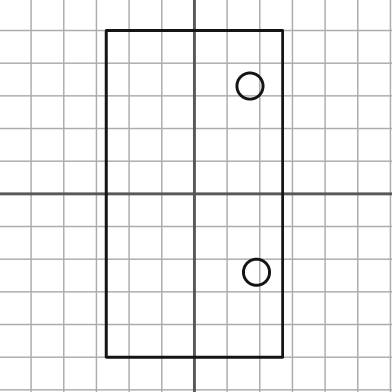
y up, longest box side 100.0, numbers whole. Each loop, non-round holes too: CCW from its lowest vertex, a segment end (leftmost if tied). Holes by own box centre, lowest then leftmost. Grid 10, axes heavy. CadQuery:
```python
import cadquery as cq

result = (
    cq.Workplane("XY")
    .moveTo(-27.0, -50.0)
    .lineTo(27.0, -50.0)
    .lineTo(27.0, 50.0)
    .lineTo(-27.0, 50.0)
    .close()
    .moveTo(19.0, -24.0)
    .circle(4.0)
    .moveTo(17.0, 33.0)
    .circle(4.0)
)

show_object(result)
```